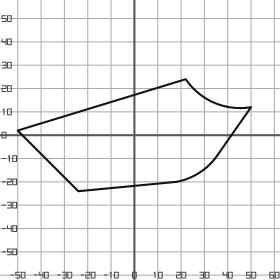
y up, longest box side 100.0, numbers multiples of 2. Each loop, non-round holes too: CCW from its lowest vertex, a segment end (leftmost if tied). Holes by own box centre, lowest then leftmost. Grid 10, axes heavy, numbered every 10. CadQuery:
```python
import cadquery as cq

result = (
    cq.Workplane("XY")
    .moveTo(-24.0, -24.0)
    .lineTo(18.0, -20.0)
    .threePointArc((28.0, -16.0), (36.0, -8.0))
    .lineTo(50.0, 12.0)
    .threePointArc((34.0, 14.0), (22.0, 24.0))
    .lineTo(-50.0, 2.0)
    .close()
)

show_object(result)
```